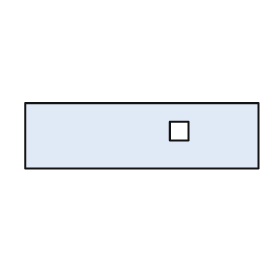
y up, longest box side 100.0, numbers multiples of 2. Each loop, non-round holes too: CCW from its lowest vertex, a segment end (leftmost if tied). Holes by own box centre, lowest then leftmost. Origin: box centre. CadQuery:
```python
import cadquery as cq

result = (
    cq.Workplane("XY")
    .moveTo(-50.0, -14.0)
    .lineTo(50.0, -14.0)
    .lineTo(50.0, 14.0)
    .lineTo(-50.0, 14.0)
    .close()
    .moveTo(12.0, -2.0)
    .lineTo(20.0, -2.0)
    .lineTo(20.0, 6.0)
    .lineTo(12.0, 6.0)
    .close()
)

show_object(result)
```